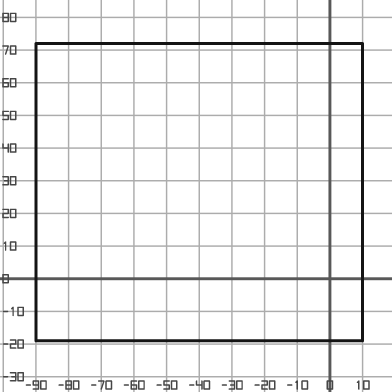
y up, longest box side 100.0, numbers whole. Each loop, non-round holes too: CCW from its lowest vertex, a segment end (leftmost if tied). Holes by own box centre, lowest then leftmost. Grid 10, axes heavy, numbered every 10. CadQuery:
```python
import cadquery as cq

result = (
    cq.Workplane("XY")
    .moveTo(-90.0, -19.0)
    .lineTo(10.0, -19.0)
    .lineTo(10.0, 72.0)
    .lineTo(-90.0, 72.0)
    .close()
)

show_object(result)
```